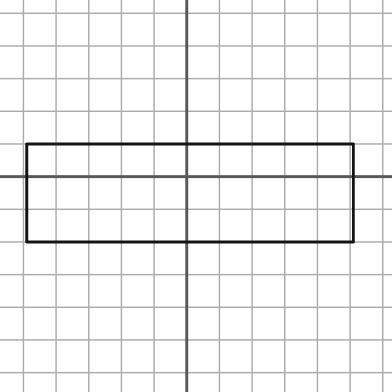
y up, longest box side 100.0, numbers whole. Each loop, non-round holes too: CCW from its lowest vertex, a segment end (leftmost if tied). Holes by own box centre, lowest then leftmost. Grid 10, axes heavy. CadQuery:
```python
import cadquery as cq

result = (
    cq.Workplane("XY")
    .moveTo(-49.0, -20.0)
    .lineTo(51.0, -20.0)
    .lineTo(51.0, 10.0)
    .lineTo(-49.0, 10.0)
    .close()
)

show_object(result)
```